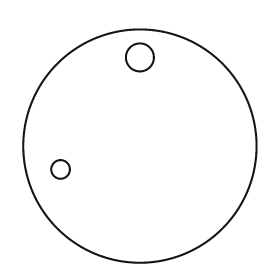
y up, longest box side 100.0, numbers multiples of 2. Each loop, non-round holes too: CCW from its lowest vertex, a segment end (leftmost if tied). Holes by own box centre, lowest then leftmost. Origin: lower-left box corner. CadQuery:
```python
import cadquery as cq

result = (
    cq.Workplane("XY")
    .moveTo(50.0, 50.0)
    .circle(50.0)
    .moveTo(16.0, 40.0)
    .circle(4.0)
    .moveTo(50.0, 88.0)
    .circle(6.0)
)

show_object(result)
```